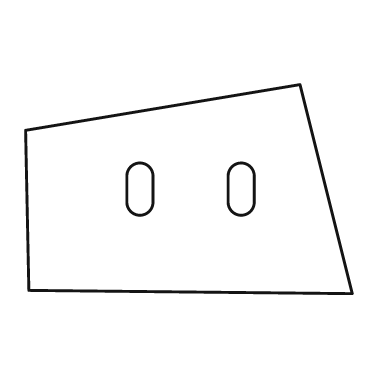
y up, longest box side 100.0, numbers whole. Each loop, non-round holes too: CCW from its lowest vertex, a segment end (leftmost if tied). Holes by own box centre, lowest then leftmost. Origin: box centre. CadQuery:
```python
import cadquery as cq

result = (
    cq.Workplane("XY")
    .moveTo(50.0, -32.0)
    .lineTo(34.0, 32.0)
    .lineTo(-50.0, 18.0)
    .lineTo(-49.0, -31.0)
    .close()
    .moveTo(-19.0, -4.0)
    .threePointArc((-15.0, -8.0), (-11.0, -4.0))
    .lineTo(-11.0, 4.0)
    .threePointArc((-15.0, 8.0), (-19.0, 4.0))
    .close()
    .moveTo(12.0, -4.0)
    .threePointArc((16.0, -8.0), (20.0, -4.0))
    .lineTo(20.0, 4.0)
    .threePointArc((16.0, 8.0), (12.0, 4.0))
    .close()
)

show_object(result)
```